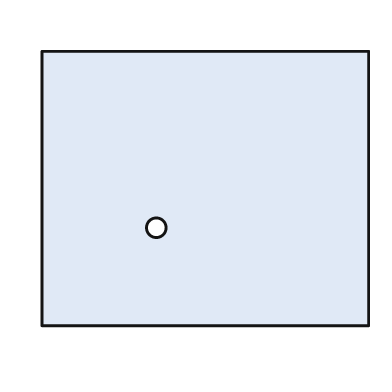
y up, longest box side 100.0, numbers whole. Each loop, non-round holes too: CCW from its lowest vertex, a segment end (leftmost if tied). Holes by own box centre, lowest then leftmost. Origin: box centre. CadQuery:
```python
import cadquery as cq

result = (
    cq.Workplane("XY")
    .moveTo(-50.0, -42.0)
    .lineTo(50.0, -42.0)
    .lineTo(50.0, 42.0)
    .lineTo(-50.0, 42.0)
    .close()
    .moveTo(-15.0, -12.0)
    .circle(3.0)
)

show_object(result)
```